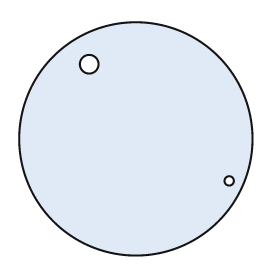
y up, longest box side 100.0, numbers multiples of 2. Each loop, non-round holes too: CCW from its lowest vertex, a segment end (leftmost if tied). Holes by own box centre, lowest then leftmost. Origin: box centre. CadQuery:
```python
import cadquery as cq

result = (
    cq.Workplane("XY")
    .moveTo(0.0, 0.0)
    .circle(50.0)
    .moveTo(40.0, -18.0)
    .circle(2.0)
    .moveTo(-20.0, 32.0)
    .circle(4.0)
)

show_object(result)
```